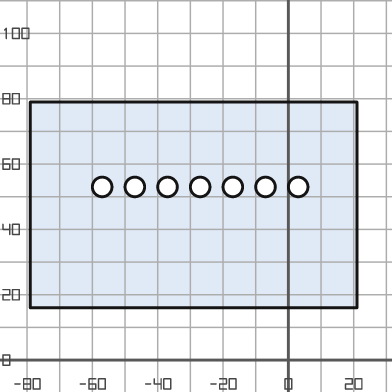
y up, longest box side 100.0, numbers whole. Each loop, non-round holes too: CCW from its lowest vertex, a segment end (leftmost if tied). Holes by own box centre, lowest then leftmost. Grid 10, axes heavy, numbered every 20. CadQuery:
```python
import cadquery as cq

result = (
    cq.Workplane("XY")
    .moveTo(-79.0, 16.0)
    .lineTo(21.0, 16.0)
    .lineTo(21.0, 79.0)
    .lineTo(-79.0, 79.0)
    .close()
    .moveTo(-57.0, 53.0)
    .circle(3.0)
    .moveTo(-47.0, 53.0)
    .circle(3.0)
    .moveTo(-37.0, 53.0)
    .circle(3.0)
    .moveTo(-27.0, 53.0)
    .circle(3.0)
    .moveTo(-17.0, 53.0)
    .circle(3.0)
    .moveTo(-7.0, 53.0)
    .circle(3.0)
    .moveTo(3.0, 53.0)
    .circle(3.0)
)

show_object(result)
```